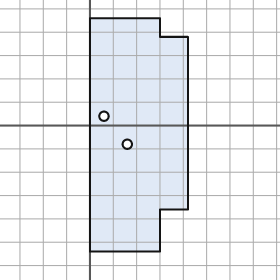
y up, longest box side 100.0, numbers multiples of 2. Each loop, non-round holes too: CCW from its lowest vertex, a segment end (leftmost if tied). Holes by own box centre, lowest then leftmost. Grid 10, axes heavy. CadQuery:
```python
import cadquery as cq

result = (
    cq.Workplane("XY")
    .moveTo(0.0, -54.0)
    .lineTo(30.0, -54.0)
    .lineTo(30.0, -36.0)
    .lineTo(42.0, -36.0)
    .lineTo(42.0, 38.0)
    .lineTo(30.0, 38.0)
    .lineTo(30.0, 46.0)
    .lineTo(0.0, 46.0)
    .close()
    .moveTo(16.0, -8.0)
    .circle(2.0)
    .moveTo(6.0, 4.0)
    .circle(2.0)
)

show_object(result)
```